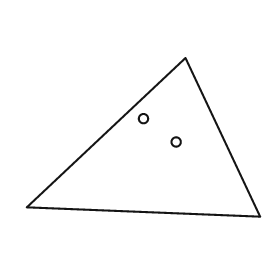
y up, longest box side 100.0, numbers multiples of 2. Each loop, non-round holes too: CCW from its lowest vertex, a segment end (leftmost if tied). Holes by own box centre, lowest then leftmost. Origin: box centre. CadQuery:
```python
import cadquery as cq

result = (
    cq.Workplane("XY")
    .moveTo(50.0, -34.0)
    .lineTo(18.0, 34.0)
    .lineTo(-50.0, -30.0)
    .close()
    .moveTo(14.0, -2.0)
    .circle(2.0)
    .moveTo(0.0, 8.0)
    .circle(2.0)
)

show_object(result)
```